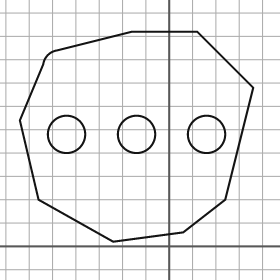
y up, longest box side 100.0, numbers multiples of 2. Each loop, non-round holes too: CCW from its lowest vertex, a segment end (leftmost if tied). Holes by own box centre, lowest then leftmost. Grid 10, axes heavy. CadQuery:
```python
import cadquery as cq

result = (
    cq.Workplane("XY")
    .moveTo(-24.0, 2.0)
    .lineTo(6.0, 6.0)
    .lineTo(24.0, 20.0)
    .lineTo(36.0, 68.0)
    .lineTo(12.0, 92.0)
    .lineTo(-16.0, 92.0)
    .lineTo(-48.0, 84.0)
    .threePointArc((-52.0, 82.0), (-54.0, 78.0))
    .lineTo(-64.0, 54.0)
    .lineTo(-56.0, 20.0)
    .close()
    .moveTo(-44.0, 48.0)
    .circle(8.0)
    .moveTo(-14.0, 48.0)
    .circle(8.0)
    .moveTo(16.0, 48.0)
    .circle(8.0)
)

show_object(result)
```